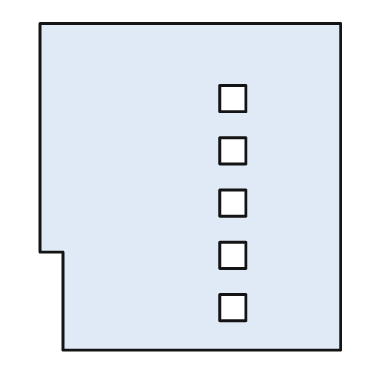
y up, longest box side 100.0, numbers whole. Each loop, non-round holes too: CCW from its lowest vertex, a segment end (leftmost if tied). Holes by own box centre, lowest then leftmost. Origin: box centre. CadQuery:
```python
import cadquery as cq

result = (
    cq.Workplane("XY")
    .moveTo(-39.0, -50.0)
    .lineTo(46.0, -50.0)
    .lineTo(46.0, 50.0)
    .lineTo(-46.0, 50.0)
    .lineTo(-46.0, -20.0)
    .lineTo(-39.0, -20.0)
    .close()
    .moveTo(9.0, -41.0)
    .lineTo(17.0, -41.0)
    .lineTo(17.0, -33.0)
    .lineTo(9.0, -33.0)
    .close()
    .moveTo(9.0, -25.0)
    .lineTo(17.0, -25.0)
    .lineTo(17.0, -17.0)
    .lineTo(9.0, -17.0)
    .close()
    .moveTo(9.0, -9.0)
    .lineTo(17.0, -9.0)
    .lineTo(17.0, -1.0)
    .lineTo(9.0, -1.0)
    .close()
    .moveTo(9.0, 7.0)
    .lineTo(17.0, 7.0)
    .lineTo(17.0, 15.0)
    .lineTo(9.0, 15.0)
    .close()
    .moveTo(9.0, 23.0)
    .lineTo(17.0, 23.0)
    .lineTo(17.0, 31.0)
    .lineTo(9.0, 31.0)
    .close()
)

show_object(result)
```